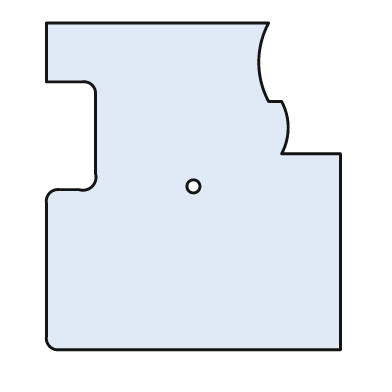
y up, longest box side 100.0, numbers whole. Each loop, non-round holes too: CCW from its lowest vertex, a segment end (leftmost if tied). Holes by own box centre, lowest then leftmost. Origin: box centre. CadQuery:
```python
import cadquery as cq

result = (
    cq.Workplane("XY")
    .moveTo(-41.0, -50.0)
    .lineTo(45.0, -50.0)
    .lineTo(45.0, 10.0)
    .lineTo(27.0, 10.0)
    .threePointArc((29.0, 18.0), (27.0, 26.0))
    .lineTo(23.0, 26.0)
    .threePointArc((20.0, 38.0), (23.0, 50.0))
    .lineTo(-45.0, 50.0)
    .lineTo(-45.0, 32.0)
    .lineTo(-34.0, 32.0)
    .threePointArc((-31.0, 31.0), (-30.0, 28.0))
    .lineTo(-30.0, 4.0)
    .threePointArc((-31.0, 0.0), (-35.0, -1.0))
    .lineTo(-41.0, -1.0)
    .threePointArc((-44.0, -2.0), (-45.0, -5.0))
    .lineTo(-45.0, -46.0)
    .threePointArc((-44.0, -49.0), (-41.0, -50.0))
    .close()
    .moveTo(0.0, 0.0)
    .circle(2.0)
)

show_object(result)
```